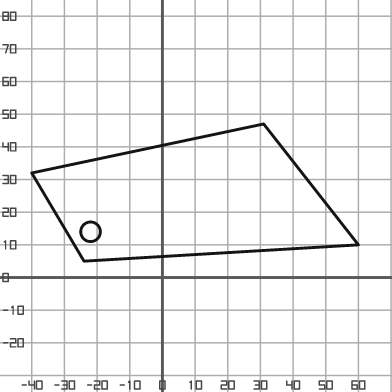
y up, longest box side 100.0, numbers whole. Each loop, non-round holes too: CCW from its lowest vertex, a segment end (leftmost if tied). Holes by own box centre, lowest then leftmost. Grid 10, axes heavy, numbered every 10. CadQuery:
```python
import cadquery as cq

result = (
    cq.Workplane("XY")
    .moveTo(-24.0, 5.0)
    .lineTo(60.0, 10.0)
    .lineTo(31.0, 47.0)
    .lineTo(-40.0, 32.0)
    .close()
    .moveTo(-22.0, 14.0)
    .circle(3.0)
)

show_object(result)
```